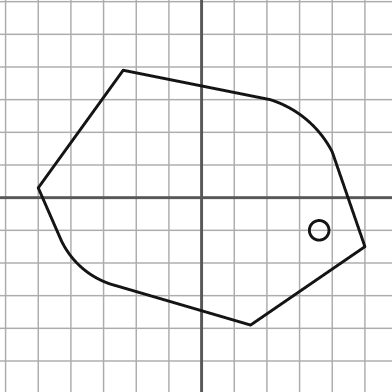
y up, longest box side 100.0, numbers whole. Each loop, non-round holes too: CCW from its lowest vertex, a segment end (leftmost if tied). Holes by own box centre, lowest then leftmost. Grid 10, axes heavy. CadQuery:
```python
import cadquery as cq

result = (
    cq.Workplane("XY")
    .moveTo(15.0, -39.0)
    .lineTo(50.0, -15.0)
    .lineTo(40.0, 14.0)
    .threePointArc((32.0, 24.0), (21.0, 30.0))
    .lineTo(-24.0, 39.0)
    .lineTo(-50.0, 3.0)
    .lineTo(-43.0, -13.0)
    .threePointArc((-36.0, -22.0), (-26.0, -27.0))
    .close()
    .moveTo(36.0, -10.0)
    .circle(3.0)
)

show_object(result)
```